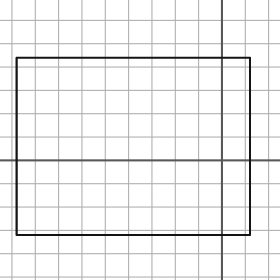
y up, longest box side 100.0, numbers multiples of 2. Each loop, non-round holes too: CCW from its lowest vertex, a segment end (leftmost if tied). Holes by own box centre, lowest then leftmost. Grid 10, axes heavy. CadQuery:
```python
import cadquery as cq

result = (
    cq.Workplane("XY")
    .moveTo(-88.0, -32.0)
    .lineTo(12.0, -32.0)
    .lineTo(12.0, 44.0)
    .lineTo(-88.0, 44.0)
    .close()
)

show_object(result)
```